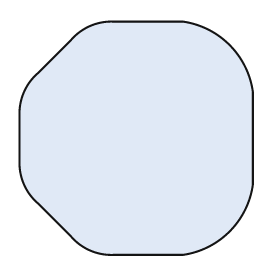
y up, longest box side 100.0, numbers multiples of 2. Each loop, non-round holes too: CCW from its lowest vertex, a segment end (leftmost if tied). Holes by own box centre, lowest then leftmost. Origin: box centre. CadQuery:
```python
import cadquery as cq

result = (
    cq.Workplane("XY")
    .moveTo(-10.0, -50.0)
    .lineTo(20.0, -50.0)
    .threePointArc((40.0, -40.0), (50.0, -20.0))
    .lineTo(50.0, 20.0)
    .threePointArc((40.0, 40.0), (20.0, 50.0))
    .lineTo(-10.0, 50.0)
    .threePointArc((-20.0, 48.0), (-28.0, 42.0))
    .lineTo(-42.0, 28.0)
    .threePointArc((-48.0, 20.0), (-50.0, 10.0))
    .lineTo(-50.0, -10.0)
    .threePointArc((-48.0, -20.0), (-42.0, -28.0))
    .lineTo(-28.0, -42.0)
    .threePointArc((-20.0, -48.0), (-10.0, -50.0))
    .close()
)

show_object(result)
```